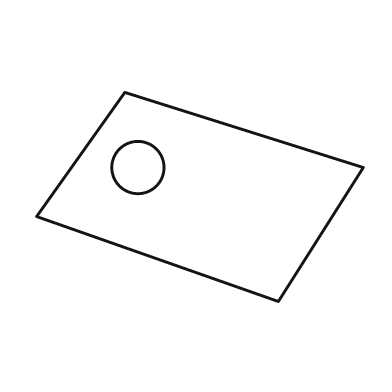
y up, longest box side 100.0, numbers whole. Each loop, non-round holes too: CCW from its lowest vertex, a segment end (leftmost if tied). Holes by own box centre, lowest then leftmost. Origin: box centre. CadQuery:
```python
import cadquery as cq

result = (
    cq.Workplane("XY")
    .moveTo(24.0, -32.0)
    .lineTo(50.0, 9.0)
    .lineTo(-23.0, 32.0)
    .lineTo(-50.0, -6.0)
    .close()
    .moveTo(-19.0, 9.0)
    .circle(8.0)
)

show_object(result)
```